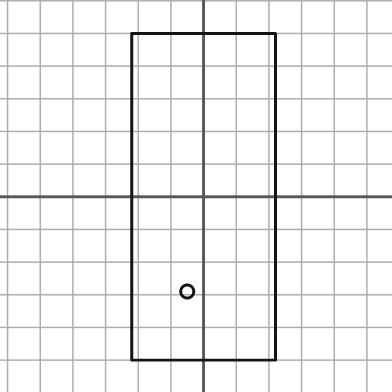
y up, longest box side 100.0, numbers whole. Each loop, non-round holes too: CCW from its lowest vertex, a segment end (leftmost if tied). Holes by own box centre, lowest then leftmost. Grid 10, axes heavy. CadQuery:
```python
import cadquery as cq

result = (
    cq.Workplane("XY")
    .moveTo(-22.0, -50.0)
    .lineTo(22.0, -50.0)
    .lineTo(22.0, 50.0)
    .lineTo(-22.0, 50.0)
    .close()
    .moveTo(-5.0, -29.0)
    .circle(2.0)
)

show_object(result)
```